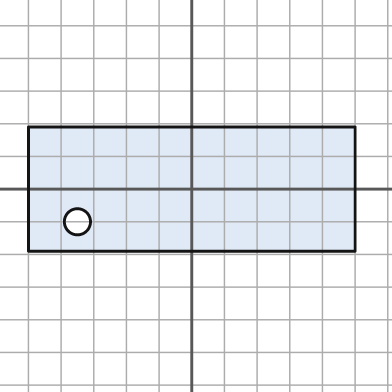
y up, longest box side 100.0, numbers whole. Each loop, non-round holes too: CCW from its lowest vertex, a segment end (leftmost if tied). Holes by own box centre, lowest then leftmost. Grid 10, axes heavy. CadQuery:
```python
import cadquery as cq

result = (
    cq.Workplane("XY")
    .moveTo(-50.0, -19.0)
    .lineTo(50.0, -19.0)
    .lineTo(50.0, 19.0)
    .lineTo(-50.0, 19.0)
    .close()
    .moveTo(-35.0, -10.0)
    .circle(4.0)
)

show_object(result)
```